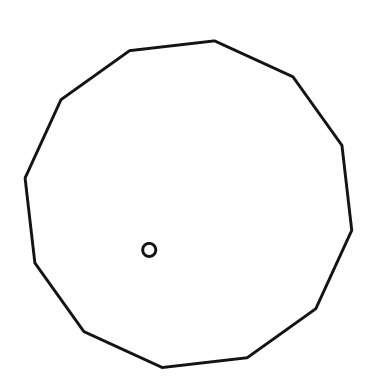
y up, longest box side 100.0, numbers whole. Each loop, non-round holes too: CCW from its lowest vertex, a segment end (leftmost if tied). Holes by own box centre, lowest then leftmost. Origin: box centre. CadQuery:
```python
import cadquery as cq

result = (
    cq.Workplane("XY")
    .moveTo(-8.0, -50.0)
    .lineTo(18.0, -47.0)
    .lineTo(39.0, -32.0)
    .lineTo(50.0, -8.0)
    .lineTo(47.0, 18.0)
    .lineTo(32.0, 39.0)
    .lineTo(8.0, 50.0)
    .lineTo(-18.0, 47.0)
    .lineTo(-39.0, 32.0)
    .lineTo(-50.0, 8.0)
    .lineTo(-47.0, -18.0)
    .lineTo(-32.0, -39.0)
    .close()
    .moveTo(-12.0, -14.0)
    .circle(2.0)
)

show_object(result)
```